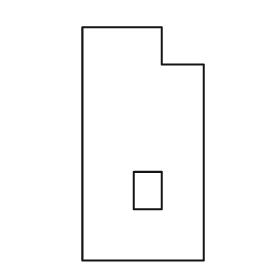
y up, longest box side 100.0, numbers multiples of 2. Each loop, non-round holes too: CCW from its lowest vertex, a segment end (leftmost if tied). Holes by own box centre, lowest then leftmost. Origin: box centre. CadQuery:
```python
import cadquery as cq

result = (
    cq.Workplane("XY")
    .moveTo(-26.0, -50.0)
    .lineTo(26.0, -50.0)
    .lineTo(26.0, 34.0)
    .lineTo(8.0, 34.0)
    .lineTo(8.0, 50.0)
    .lineTo(-26.0, 50.0)
    .close()
    .moveTo(-4.0, -28.0)
    .lineTo(8.0, -28.0)
    .lineTo(8.0, -12.0)
    .lineTo(-4.0, -12.0)
    .close()
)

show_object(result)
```